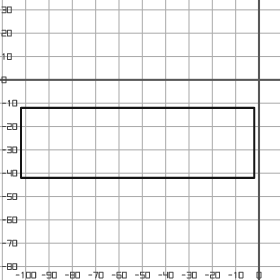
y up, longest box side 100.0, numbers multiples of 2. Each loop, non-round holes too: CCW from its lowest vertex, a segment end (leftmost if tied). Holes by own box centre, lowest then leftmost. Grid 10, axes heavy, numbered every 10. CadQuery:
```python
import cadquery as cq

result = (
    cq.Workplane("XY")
    .moveTo(-102.0, -42.0)
    .lineTo(-2.0, -42.0)
    .lineTo(-2.0, -12.0)
    .lineTo(-102.0, -12.0)
    .close()
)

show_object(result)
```